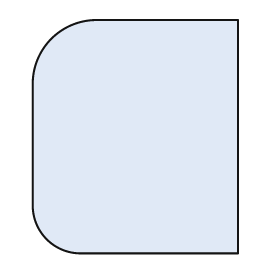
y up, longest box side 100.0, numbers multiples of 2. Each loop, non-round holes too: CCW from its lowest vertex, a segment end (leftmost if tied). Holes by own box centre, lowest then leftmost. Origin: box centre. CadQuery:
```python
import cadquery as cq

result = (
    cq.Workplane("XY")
    .moveTo(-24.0, -50.0)
    .lineTo(44.0, -50.0)
    .lineTo(44.0, 50.0)
    .lineTo(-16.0, 50.0)
    .threePointArc((-36.0, 42.0), (-44.0, 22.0))
    .lineTo(-44.0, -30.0)
    .threePointArc((-38.0, -44.0), (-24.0, -50.0))
    .close()
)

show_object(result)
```